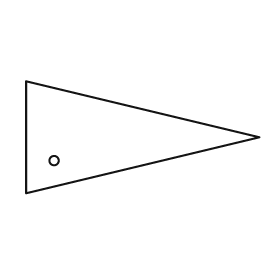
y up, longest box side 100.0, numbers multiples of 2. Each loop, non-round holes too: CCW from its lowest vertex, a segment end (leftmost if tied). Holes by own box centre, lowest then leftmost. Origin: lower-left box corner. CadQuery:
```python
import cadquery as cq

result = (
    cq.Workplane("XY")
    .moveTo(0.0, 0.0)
    .lineTo(100.0, 24.0)
    .lineTo(0.0, 48.0)
    .close()
    .moveTo(12.0, 14.0)
    .circle(2.0)
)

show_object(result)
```